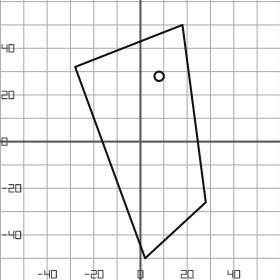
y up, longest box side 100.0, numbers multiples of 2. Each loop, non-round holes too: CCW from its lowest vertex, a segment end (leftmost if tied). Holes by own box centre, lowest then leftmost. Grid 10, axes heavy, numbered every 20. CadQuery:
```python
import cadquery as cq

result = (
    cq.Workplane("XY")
    .moveTo(2.0, -50.0)
    .lineTo(28.0, -26.0)
    .lineTo(18.0, 50.0)
    .lineTo(-28.0, 32.0)
    .close()
    .moveTo(8.0, 28.0)
    .circle(2.0)
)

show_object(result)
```